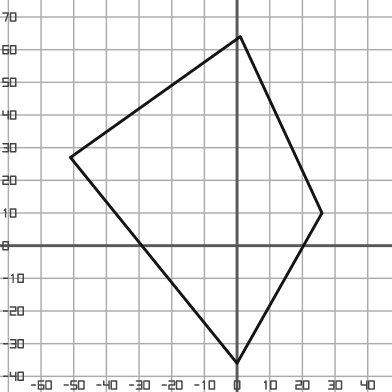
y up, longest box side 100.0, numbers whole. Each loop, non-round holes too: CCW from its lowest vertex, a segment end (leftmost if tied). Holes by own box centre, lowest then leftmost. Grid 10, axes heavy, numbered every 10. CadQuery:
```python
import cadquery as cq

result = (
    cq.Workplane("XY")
    .moveTo(0.0, -36.0)
    .lineTo(26.0, 10.0)
    .lineTo(1.0, 64.0)
    .lineTo(-51.0, 27.0)
    .close()
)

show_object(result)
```